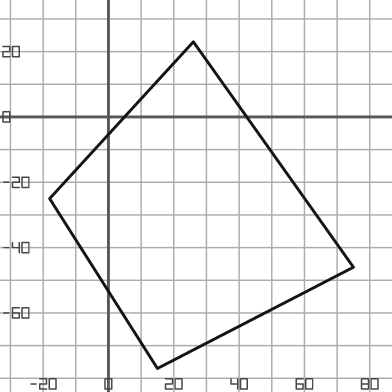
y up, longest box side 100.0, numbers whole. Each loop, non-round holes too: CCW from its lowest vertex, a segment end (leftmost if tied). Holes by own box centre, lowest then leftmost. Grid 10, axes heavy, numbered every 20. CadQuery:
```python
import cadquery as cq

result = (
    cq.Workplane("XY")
    .moveTo(15.0, -77.0)
    .lineTo(75.0, -46.0)
    .lineTo(26.0, 23.0)
    .lineTo(-18.0, -25.0)
    .close()
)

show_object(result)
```